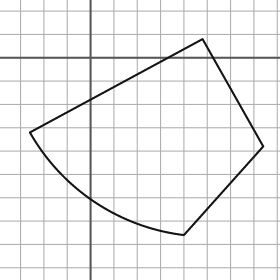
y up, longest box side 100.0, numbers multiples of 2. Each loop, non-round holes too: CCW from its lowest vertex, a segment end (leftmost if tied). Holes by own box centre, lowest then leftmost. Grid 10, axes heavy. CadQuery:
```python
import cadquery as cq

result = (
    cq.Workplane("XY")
    .moveTo(40.0, -76.0)
    .lineTo(74.0, -38.0)
    .lineTo(48.0, 8.0)
    .lineTo(-26.0, -32.0)
    .threePointArc((2.0, -62.0), (40.0, -76.0))
    .close()
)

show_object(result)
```